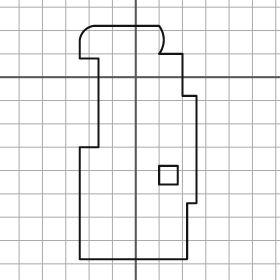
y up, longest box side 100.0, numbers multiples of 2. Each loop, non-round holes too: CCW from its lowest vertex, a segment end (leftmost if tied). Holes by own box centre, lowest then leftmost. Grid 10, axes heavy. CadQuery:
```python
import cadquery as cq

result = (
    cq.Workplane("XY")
    .moveTo(-24.0, -78.0)
    .lineTo(22.0, -78.0)
    .lineTo(22.0, -54.0)
    .lineTo(26.0, -54.0)
    .lineTo(26.0, -8.0)
    .lineTo(20.0, -8.0)
    .lineTo(20.0, 10.0)
    .lineTo(10.0, 10.0)
    .threePointArc((12.0, 16.0), (10.0, 22.0))
    .lineTo(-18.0, 22.0)
    .threePointArc((-22.0, 20.0), (-24.0, 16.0))
    .lineTo(-24.0, 8.0)
    .lineTo(-16.0, 8.0)
    .lineTo(-16.0, -30.0)
    .lineTo(-24.0, -30.0)
    .close()
    .moveTo(10.0, -46.0)
    .lineTo(18.0, -46.0)
    .lineTo(18.0, -38.0)
    .lineTo(10.0, -38.0)
    .close()
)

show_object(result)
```